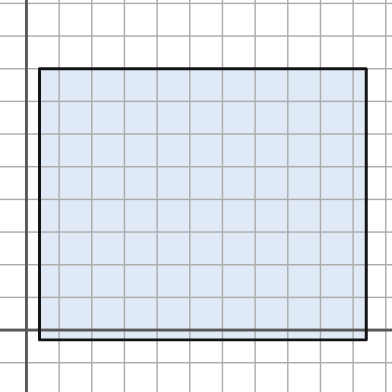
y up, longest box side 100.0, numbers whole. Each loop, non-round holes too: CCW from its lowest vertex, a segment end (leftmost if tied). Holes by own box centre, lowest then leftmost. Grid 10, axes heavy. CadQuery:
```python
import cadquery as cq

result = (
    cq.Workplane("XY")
    .moveTo(4.0, -3.0)
    .lineTo(104.0, -3.0)
    .lineTo(104.0, 80.0)
    .lineTo(4.0, 80.0)
    .close()
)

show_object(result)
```